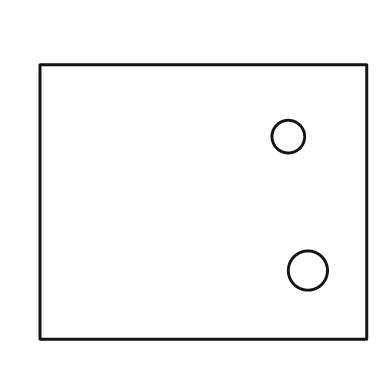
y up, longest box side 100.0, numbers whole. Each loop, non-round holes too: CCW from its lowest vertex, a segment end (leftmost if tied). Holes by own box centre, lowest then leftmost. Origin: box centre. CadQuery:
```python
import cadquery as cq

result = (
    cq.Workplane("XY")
    .moveTo(-50.0, -42.0)
    .lineTo(50.0, -42.0)
    .lineTo(50.0, 42.0)
    .lineTo(-50.0, 42.0)
    .close()
    .moveTo(32.0, -21.0)
    .circle(6.0)
    .moveTo(26.0, 20.0)
    .circle(5.0)
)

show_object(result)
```